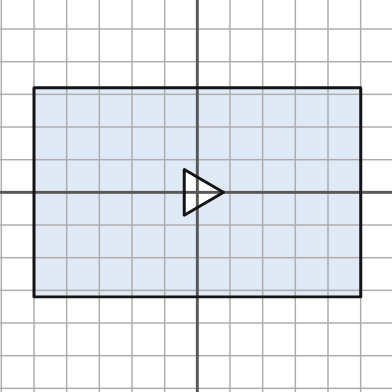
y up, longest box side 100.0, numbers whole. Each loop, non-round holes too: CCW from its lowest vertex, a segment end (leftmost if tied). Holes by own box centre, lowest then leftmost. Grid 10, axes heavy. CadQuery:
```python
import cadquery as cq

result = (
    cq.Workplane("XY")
    .moveTo(-50.0, -32.0)
    .lineTo(50.0, -32.0)
    .lineTo(50.0, 32.0)
    .lineTo(-50.0, 32.0)
    .close()
    .moveTo(-4.0, -7.0)
    .lineTo(8.0, 0.0)
    .lineTo(-4.0, 7.0)
    .close()
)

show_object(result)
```